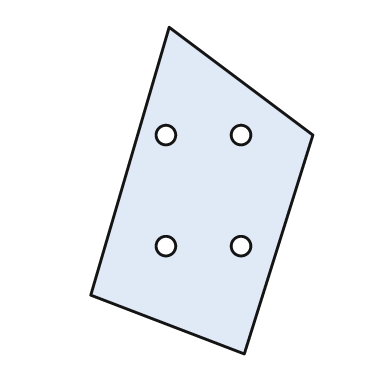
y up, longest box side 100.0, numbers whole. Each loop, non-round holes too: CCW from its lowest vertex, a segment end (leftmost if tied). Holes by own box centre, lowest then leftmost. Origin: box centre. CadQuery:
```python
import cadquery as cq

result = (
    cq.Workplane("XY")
    .moveTo(13.0, -50.0)
    .lineTo(34.0, 17.0)
    .lineTo(-10.0, 50.0)
    .lineTo(-34.0, -32.0)
    .close()
    .moveTo(-11.0, -17.0)
    .circle(3.0)
    .moveTo(12.0, -17.0)
    .circle(3.0)
    .moveTo(-11.0, 17.0)
    .circle(3.0)
    .moveTo(12.0, 17.0)
    .circle(3.0)
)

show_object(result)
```